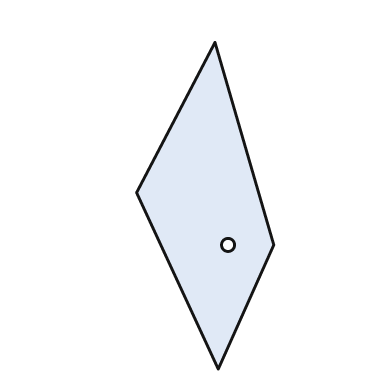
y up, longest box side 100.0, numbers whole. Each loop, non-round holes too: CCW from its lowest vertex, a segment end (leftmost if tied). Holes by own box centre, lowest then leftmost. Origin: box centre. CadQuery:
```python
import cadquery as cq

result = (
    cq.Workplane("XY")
    .moveTo(4.0, -50.0)
    .lineTo(21.0, -12.0)
    .lineTo(3.0, 50.0)
    .lineTo(-21.0, 4.0)
    .close()
    .moveTo(7.0, -12.0)
    .circle(2.0)
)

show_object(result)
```